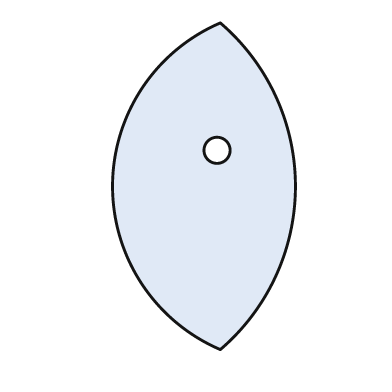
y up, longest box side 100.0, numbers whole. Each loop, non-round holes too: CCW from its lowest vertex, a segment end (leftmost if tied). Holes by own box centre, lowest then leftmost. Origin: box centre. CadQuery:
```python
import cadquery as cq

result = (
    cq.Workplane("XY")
    .moveTo(5.0, -50.0)
    .threePointArc((28.0, 0.0), (5.0, 50.0))
    .threePointArc((-28.0, 0.0), (5.0, -50.0))
    .close()
    .moveTo(4.0, 11.0)
    .circle(4.0)
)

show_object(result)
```